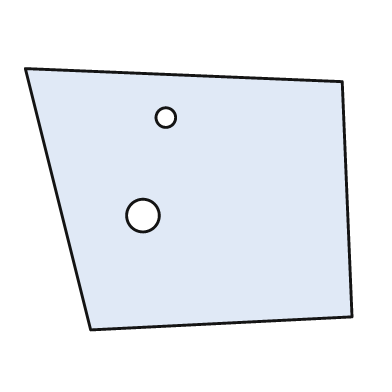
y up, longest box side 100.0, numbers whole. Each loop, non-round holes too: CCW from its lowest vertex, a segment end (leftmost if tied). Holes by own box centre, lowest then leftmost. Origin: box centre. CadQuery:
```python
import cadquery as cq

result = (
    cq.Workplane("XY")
    .moveTo(-30.0, -40.0)
    .lineTo(50.0, -36.0)
    .lineTo(47.0, 36.0)
    .lineTo(-50.0, 40.0)
    .close()
    .moveTo(-14.0, -5.0)
    .circle(5.0)
    .moveTo(-7.0, 25.0)
    .circle(3.0)
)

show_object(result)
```